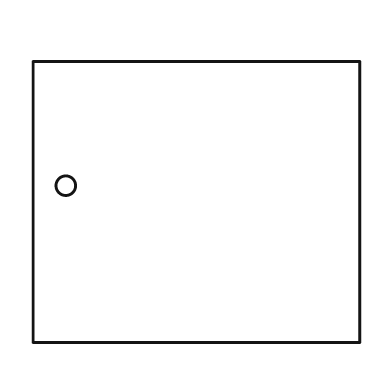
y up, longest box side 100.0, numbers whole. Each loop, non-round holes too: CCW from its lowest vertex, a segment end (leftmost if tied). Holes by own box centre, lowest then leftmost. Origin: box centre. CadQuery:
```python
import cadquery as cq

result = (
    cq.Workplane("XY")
    .moveTo(-50.0, -43.0)
    .lineTo(50.0, -43.0)
    .lineTo(50.0, 43.0)
    .lineTo(-50.0, 43.0)
    .close()
    .moveTo(-40.0, 5.0)
    .circle(3.0)
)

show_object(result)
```